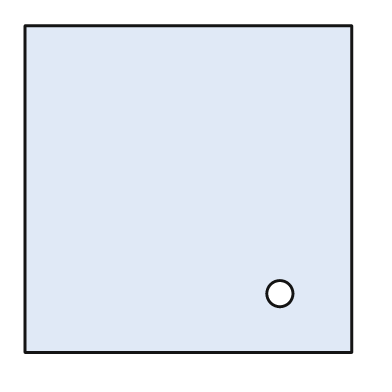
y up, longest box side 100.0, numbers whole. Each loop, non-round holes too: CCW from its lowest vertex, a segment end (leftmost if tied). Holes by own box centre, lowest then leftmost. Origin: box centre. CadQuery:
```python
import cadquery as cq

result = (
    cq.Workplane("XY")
    .moveTo(-50.0, -50.0)
    .lineTo(50.0, -50.0)
    .lineTo(50.0, 50.0)
    .lineTo(-50.0, 50.0)
    .close()
    .moveTo(28.0, -32.0)
    .circle(4.0)
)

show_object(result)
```